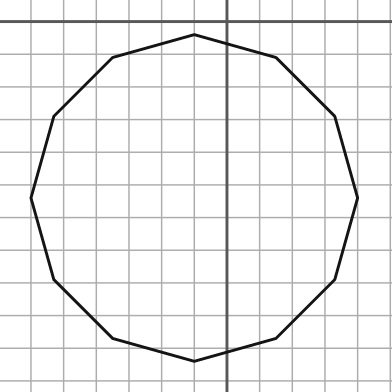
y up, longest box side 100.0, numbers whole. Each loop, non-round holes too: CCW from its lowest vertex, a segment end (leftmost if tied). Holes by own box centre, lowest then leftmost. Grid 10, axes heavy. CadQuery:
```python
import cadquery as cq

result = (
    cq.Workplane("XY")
    .moveTo(-10.0, -104.0)
    .lineTo(15.0, -97.0)
    .lineTo(33.0, -79.0)
    .lineTo(40.0, -54.0)
    .lineTo(33.0, -29.0)
    .lineTo(15.0, -11.0)
    .lineTo(-10.0, -4.0)
    .lineTo(-35.0, -11.0)
    .lineTo(-53.0, -29.0)
    .lineTo(-60.0, -54.0)
    .lineTo(-53.0, -79.0)
    .lineTo(-35.0, -97.0)
    .close()
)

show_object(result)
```